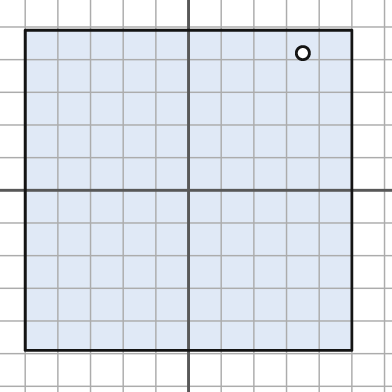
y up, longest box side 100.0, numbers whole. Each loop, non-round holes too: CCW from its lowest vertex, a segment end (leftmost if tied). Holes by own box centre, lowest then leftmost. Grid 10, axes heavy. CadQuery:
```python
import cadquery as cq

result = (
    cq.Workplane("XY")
    .moveTo(-50.0, -49.0)
    .lineTo(50.0, -49.0)
    .lineTo(50.0, 49.0)
    .lineTo(-50.0, 49.0)
    .close()
    .moveTo(35.0, 42.0)
    .circle(2.0)
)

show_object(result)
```